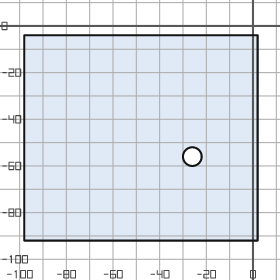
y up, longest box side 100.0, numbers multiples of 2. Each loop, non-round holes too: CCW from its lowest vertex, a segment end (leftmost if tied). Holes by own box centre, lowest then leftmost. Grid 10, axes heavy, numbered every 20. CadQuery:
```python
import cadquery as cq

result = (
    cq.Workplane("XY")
    .moveTo(-98.0, -92.0)
    .lineTo(2.0, -92.0)
    .lineTo(2.0, -4.0)
    .lineTo(-98.0, -4.0)
    .close()
    .moveTo(-26.0, -56.0)
    .circle(4.0)
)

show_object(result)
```